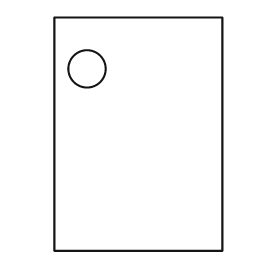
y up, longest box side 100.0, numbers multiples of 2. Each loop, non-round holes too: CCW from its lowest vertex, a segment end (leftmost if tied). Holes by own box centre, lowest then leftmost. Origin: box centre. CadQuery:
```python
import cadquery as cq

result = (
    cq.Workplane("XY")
    .moveTo(-36.0, -50.0)
    .lineTo(36.0, -50.0)
    .lineTo(36.0, 50.0)
    .lineTo(-36.0, 50.0)
    .close()
    .moveTo(-22.0, 28.0)
    .circle(8.0)
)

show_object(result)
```